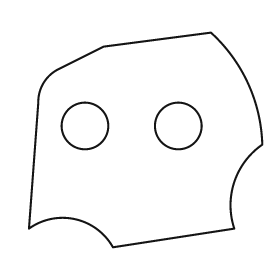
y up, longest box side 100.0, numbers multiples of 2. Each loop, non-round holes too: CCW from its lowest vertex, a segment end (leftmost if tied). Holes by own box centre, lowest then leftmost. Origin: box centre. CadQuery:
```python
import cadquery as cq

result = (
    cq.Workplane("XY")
    .moveTo(-14.0, -46.0)
    .lineTo(38.0, -38.0)
    .threePointArc((38.0, -18.0), (50.0, -2.0))
    .threePointArc((44.0, 24.0), (28.0, 46.0))
    .lineTo(-18.0, 40.0)
    .lineTo(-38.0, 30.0)
    .threePointArc((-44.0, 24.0), (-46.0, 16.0))
    .lineTo(-50.0, -38.0)
    .threePointArc((-30.0, -34.0), (-14.0, -46.0))
    .close()
    .moveTo(-26.0, 6.0)
    .circle(10.0)
    .moveTo(14.0, 6.0)
    .circle(10.0)
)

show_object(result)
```